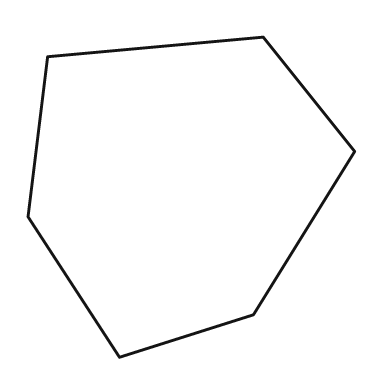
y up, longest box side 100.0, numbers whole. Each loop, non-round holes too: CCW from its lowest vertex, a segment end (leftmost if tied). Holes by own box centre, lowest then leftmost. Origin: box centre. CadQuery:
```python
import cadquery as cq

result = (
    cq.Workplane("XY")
    .moveTo(-22.0, -49.0)
    .lineTo(19.0, -36.0)
    .lineTo(50.0, 14.0)
    .lineTo(22.0, 49.0)
    .lineTo(-44.0, 43.0)
    .lineTo(-50.0, -6.0)
    .close()
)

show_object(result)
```